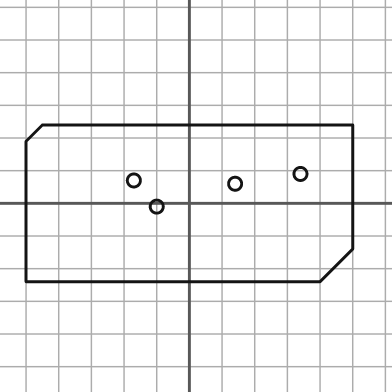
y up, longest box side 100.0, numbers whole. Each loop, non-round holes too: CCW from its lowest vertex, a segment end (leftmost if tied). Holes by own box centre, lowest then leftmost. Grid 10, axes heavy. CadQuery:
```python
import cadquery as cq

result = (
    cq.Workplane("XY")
    .moveTo(-50.0, -24.0)
    .lineTo(40.0, -24.0)
    .lineTo(50.0, -14.0)
    .lineTo(50.0, 24.0)
    .lineTo(-45.0, 24.0)
    .lineTo(-50.0, 19.0)
    .close()
    .moveTo(-10.0, -1.0)
    .circle(2.0)
    .moveTo(14.0, 6.0)
    .circle(2.0)
    .moveTo(-17.0, 7.0)
    .circle(2.0)
    .moveTo(34.0, 9.0)
    .circle(2.0)
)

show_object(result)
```